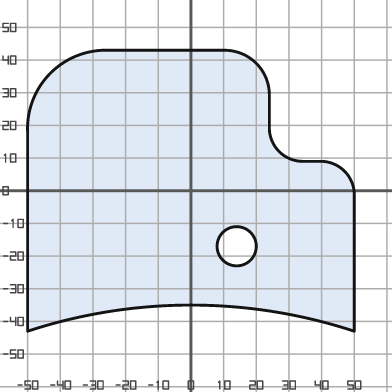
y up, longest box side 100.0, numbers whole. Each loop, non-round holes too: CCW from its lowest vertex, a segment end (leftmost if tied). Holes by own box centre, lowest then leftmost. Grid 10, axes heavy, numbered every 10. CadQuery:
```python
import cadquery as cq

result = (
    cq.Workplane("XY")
    .moveTo(-50.0, -43.0)
    .threePointArc((0.0, -35.0), (50.0, -43.0))
    .lineTo(50.0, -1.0)
    .threePointArc((47.0, 6.0), (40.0, 9.0))
    .lineTo(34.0, 9.0)
    .threePointArc((27.0, 12.0), (24.0, 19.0))
    .lineTo(24.0, 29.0)
    .threePointArc((20.0, 39.0), (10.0, 43.0))
    .lineTo(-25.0, 43.0)
    .threePointArc((-43.0, 36.0), (-50.0, 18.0))
    .close()
    .moveTo(14.0, -17.0)
    .circle(6.0)
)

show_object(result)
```